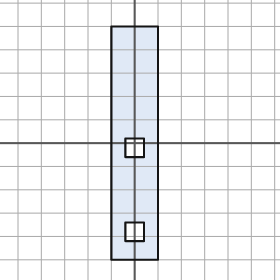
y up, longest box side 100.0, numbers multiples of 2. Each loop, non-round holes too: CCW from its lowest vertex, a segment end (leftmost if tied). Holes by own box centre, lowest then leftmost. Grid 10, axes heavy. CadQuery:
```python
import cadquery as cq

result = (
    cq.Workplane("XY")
    .moveTo(-10.0, -50.0)
    .lineTo(10.0, -50.0)
    .lineTo(10.0, 50.0)
    .lineTo(-10.0, 50.0)
    .close()
    .moveTo(-4.0, -42.0)
    .lineTo(4.0, -42.0)
    .lineTo(4.0, -34.0)
    .lineTo(-4.0, -34.0)
    .close()
    .moveTo(-4.0, -6.0)
    .lineTo(4.0, -6.0)
    .lineTo(4.0, 2.0)
    .lineTo(-4.0, 2.0)
    .close()
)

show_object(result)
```